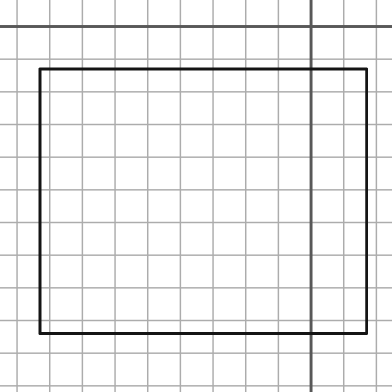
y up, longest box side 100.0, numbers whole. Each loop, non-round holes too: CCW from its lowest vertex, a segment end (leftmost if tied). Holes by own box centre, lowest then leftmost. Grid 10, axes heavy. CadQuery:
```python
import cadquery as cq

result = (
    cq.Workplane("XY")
    .moveTo(-83.0, -94.0)
    .lineTo(17.0, -94.0)
    .lineTo(17.0, -13.0)
    .lineTo(-83.0, -13.0)
    .close()
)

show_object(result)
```